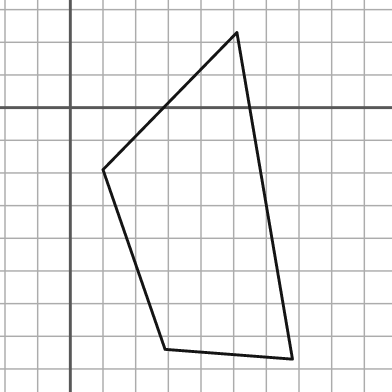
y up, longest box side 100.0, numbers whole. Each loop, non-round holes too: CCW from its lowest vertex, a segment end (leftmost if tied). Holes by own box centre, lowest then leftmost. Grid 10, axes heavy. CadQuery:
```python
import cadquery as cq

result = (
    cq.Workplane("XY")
    .moveTo(68.0, -77.0)
    .lineTo(51.0, 23.0)
    .lineTo(10.0, -19.0)
    .lineTo(29.0, -74.0)
    .close()
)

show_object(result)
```